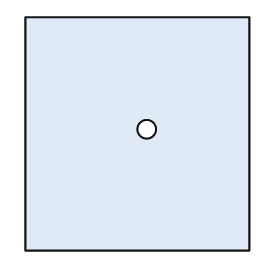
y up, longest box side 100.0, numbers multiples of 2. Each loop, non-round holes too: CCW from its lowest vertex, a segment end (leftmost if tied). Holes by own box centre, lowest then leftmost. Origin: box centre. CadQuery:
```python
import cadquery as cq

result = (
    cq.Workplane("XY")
    .moveTo(-48.0, -50.0)
    .lineTo(48.0, -50.0)
    .lineTo(48.0, 50.0)
    .lineTo(-48.0, 50.0)
    .close()
    .moveTo(4.0, 2.0)
    .circle(4.0)
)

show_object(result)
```